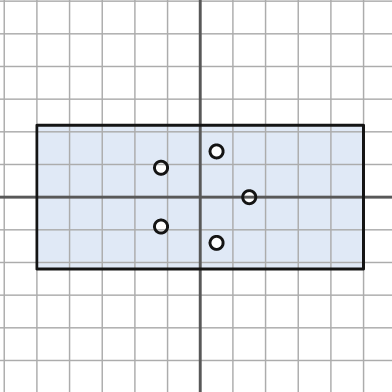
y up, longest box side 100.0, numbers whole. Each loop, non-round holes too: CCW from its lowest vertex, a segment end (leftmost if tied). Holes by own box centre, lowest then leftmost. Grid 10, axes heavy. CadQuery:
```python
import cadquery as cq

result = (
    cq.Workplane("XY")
    .moveTo(-50.0, -22.0)
    .lineTo(50.0, -22.0)
    .lineTo(50.0, 22.0)
    .lineTo(-50.0, 22.0)
    .close()
    .moveTo(5.0, -14.0)
    .circle(2.0)
    .moveTo(-12.0, -9.0)
    .circle(2.0)
    .moveTo(15.0, 0.0)
    .circle(2.0)
    .moveTo(-12.0, 9.0)
    .circle(2.0)
    .moveTo(5.0, 14.0)
    .circle(2.0)
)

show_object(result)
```